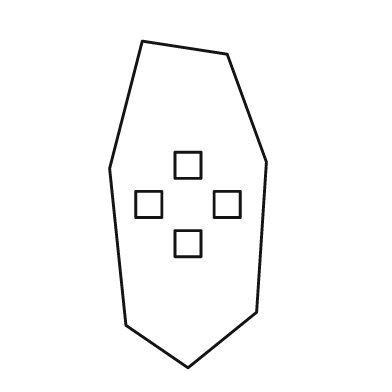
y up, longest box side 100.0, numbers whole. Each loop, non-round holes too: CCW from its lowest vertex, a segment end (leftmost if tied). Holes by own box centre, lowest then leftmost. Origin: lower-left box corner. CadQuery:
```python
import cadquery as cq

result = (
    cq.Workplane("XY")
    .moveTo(24.0, 0.0)
    .lineTo(45.0, 17.0)
    .lineTo(48.0, 63.0)
    .lineTo(36.0, 96.0)
    .lineTo(10.0, 100.0)
    .lineTo(0.0, 61.0)
    .lineTo(5.0, 13.0)
    .close()
    .moveTo(20.0, 34.0)
    .lineTo(28.0, 34.0)
    .lineTo(28.0, 42.0)
    .lineTo(20.0, 42.0)
    .close()
    .moveTo(8.0, 46.0)
    .lineTo(16.0, 46.0)
    .lineTo(16.0, 54.0)
    .lineTo(8.0, 54.0)
    .close()
    .moveTo(32.0, 46.0)
    .lineTo(40.0, 46.0)
    .lineTo(40.0, 54.0)
    .lineTo(32.0, 54.0)
    .close()
    .moveTo(20.0, 58.0)
    .lineTo(28.0, 58.0)
    .lineTo(28.0, 66.0)
    .lineTo(20.0, 66.0)
    .close()
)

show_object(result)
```